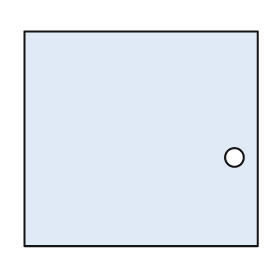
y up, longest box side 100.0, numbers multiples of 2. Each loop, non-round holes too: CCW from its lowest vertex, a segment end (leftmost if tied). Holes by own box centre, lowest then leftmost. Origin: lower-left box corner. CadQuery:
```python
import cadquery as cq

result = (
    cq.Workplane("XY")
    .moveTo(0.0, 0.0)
    .lineTo(100.0, 0.0)
    .lineTo(100.0, 92.0)
    .lineTo(0.0, 92.0)
    .close()
    .moveTo(90.0, 38.0)
    .circle(4.0)
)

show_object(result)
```